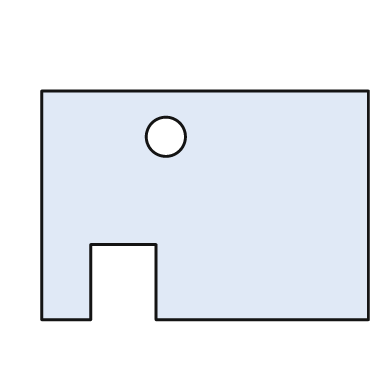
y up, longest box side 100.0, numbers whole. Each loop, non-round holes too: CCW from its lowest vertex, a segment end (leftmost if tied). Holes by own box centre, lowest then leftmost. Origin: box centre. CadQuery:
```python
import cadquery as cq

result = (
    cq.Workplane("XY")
    .moveTo(-50.0, -35.0)
    .lineTo(-35.0, -35.0)
    .lineTo(-35.0, -12.0)
    .lineTo(-15.0, -12.0)
    .lineTo(-15.0, -35.0)
    .lineTo(50.0, -35.0)
    .lineTo(50.0, 35.0)
    .lineTo(-50.0, 35.0)
    .close()
    .moveTo(-12.0, 21.0)
    .circle(6.0)
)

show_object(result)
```